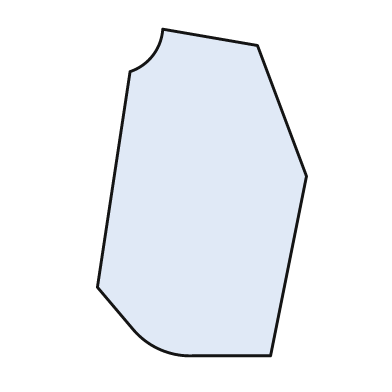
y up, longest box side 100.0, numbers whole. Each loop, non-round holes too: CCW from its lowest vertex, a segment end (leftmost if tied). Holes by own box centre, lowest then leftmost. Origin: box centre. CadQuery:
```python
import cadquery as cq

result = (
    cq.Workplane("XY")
    .moveTo(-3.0, -50.0)
    .lineTo(21.0, -50.0)
    .lineTo(32.0, 5.0)
    .lineTo(17.0, 45.0)
    .lineTo(-12.0, 50.0)
    .threePointArc((-15.0, 42.0), (-22.0, 37.0))
    .lineTo(-32.0, -29.0)
    .lineTo(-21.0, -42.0)
    .threePointArc((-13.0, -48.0), (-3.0, -50.0))
    .close()
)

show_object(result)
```